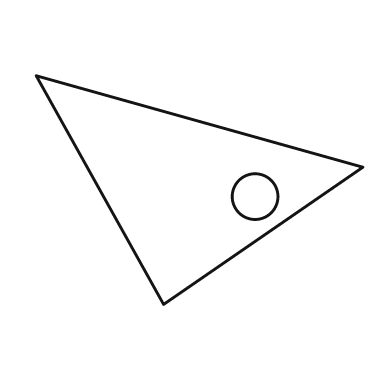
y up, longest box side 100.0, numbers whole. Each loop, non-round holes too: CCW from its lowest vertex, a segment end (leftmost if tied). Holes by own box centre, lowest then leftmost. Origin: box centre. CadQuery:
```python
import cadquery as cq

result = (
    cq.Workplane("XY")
    .moveTo(-11.0, -35.0)
    .lineTo(50.0, 7.0)
    .lineTo(-50.0, 35.0)
    .close()
    .moveTo(17.0, -2.0)
    .circle(7.0)
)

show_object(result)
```